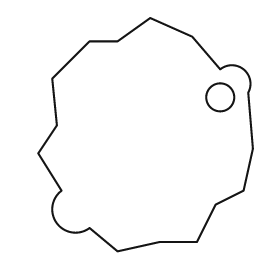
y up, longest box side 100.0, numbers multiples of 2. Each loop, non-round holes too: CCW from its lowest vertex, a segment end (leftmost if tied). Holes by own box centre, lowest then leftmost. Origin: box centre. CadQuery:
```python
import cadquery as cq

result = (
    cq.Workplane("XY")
    .moveTo(-12.0, -50.0)
    .lineTo(6.0, -46.0)
    .lineTo(22.0, -46.0)
    .lineTo(30.0, -30.0)
    .lineTo(42.0, -24.0)
    .lineTo(46.0, -6.0)
    .lineTo(44.0, 18.0)
    .threePointArc((42.0, 28.0), (32.0, 28.0))
    .lineTo(20.0, 42.0)
    .lineTo(2.0, 50.0)
    .lineTo(-12.0, 40.0)
    .lineTo(-24.0, 40.0)
    .lineTo(-40.0, 24.0)
    .lineTo(-38.0, 4.0)
    .lineTo(-46.0, -8.0)
    .lineTo(-36.0, -24.0)
    .threePointArc((-38.0, -38.0), (-24.0, -40.0))
    .close()
    .moveTo(32.0, 16.0)
    .circle(6.0)
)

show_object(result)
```